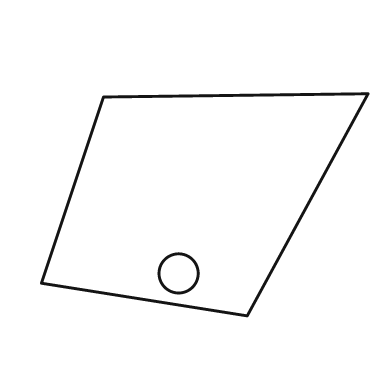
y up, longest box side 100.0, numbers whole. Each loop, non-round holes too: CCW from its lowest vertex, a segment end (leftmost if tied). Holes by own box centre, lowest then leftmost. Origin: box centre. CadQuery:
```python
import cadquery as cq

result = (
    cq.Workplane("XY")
    .moveTo(13.0, -34.0)
    .lineTo(50.0, 34.0)
    .lineTo(-31.0, 33.0)
    .lineTo(-50.0, -24.0)
    .close()
    .moveTo(-8.0, -21.0)
    .circle(6.0)
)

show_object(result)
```